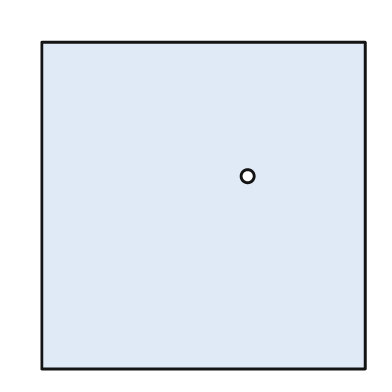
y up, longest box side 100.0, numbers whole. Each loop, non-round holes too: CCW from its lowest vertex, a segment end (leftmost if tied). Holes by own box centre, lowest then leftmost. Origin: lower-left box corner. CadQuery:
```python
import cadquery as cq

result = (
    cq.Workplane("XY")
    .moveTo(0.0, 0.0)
    .lineTo(99.0, 0.0)
    .lineTo(99.0, 100.0)
    .lineTo(0.0, 100.0)
    .close()
    .moveTo(63.0, 59.0)
    .circle(2.0)
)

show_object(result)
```